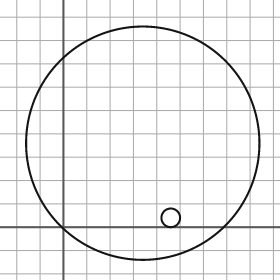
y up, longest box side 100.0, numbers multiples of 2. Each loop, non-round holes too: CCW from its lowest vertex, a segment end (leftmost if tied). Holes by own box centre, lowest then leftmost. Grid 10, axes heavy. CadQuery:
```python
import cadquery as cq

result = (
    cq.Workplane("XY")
    .moveTo(34.0, 36.0)
    .circle(50.0)
    .moveTo(46.0, 4.0)
    .circle(4.0)
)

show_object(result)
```